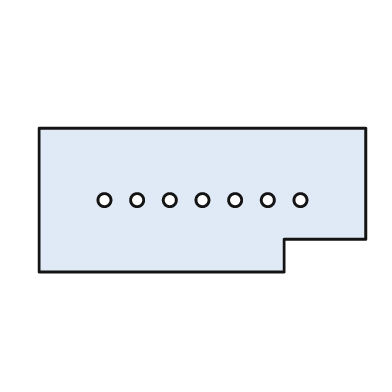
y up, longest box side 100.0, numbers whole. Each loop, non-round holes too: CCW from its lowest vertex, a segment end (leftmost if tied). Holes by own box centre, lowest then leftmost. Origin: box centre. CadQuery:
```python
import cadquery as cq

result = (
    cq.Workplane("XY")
    .moveTo(-50.0, -22.0)
    .lineTo(25.0, -22.0)
    .lineTo(25.0, -12.0)
    .lineTo(50.0, -12.0)
    .lineTo(50.0, 22.0)
    .lineTo(-50.0, 22.0)
    .close()
    .moveTo(-30.0, 0.0)
    .circle(2.0)
    .moveTo(-20.0, 0.0)
    .circle(2.0)
    .moveTo(-10.0, 0.0)
    .circle(2.0)
    .moveTo(0.0, 0.0)
    .circle(2.0)
    .moveTo(10.0, 0.0)
    .circle(2.0)
    .moveTo(20.0, 0.0)
    .circle(2.0)
    .moveTo(30.0, 0.0)
    .circle(2.0)
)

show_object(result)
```